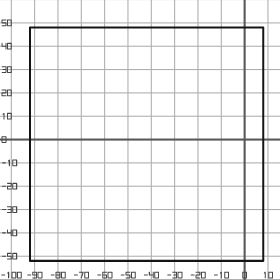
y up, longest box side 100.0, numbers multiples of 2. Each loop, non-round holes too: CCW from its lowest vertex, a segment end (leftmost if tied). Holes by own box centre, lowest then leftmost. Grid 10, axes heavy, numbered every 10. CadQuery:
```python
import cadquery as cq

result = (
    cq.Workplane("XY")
    .moveTo(-92.0, -52.0)
    .lineTo(8.0, -52.0)
    .lineTo(8.0, 48.0)
    .lineTo(-92.0, 48.0)
    .close()
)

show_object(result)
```